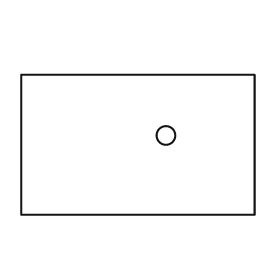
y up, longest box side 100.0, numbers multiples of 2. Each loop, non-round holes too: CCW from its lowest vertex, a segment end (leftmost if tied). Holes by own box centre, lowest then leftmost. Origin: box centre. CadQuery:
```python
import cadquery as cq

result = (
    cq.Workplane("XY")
    .moveTo(-50.0, -30.0)
    .lineTo(50.0, -30.0)
    .lineTo(50.0, 30.0)
    .lineTo(-50.0, 30.0)
    .close()
    .moveTo(12.0, 4.0)
    .circle(4.0)
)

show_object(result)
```